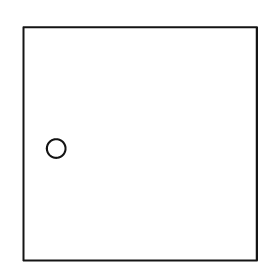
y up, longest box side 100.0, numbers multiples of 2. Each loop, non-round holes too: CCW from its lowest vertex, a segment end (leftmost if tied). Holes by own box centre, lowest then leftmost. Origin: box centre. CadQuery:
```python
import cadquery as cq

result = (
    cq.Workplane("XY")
    .moveTo(-50.0, -50.0)
    .lineTo(50.0, -50.0)
    .lineTo(50.0, 50.0)
    .lineTo(-50.0, 50.0)
    .close()
    .moveTo(-36.0, -2.0)
    .circle(4.0)
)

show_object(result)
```